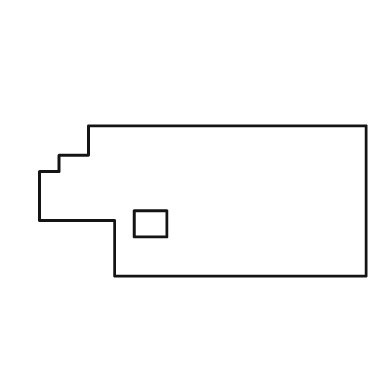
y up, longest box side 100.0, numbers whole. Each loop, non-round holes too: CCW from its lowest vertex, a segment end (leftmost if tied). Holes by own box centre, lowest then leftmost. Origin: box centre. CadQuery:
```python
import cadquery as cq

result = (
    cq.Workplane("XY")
    .moveTo(-27.0, -23.0)
    .lineTo(50.0, -23.0)
    .lineTo(50.0, 23.0)
    .lineTo(-35.0, 23.0)
    .lineTo(-35.0, 14.0)
    .lineTo(-44.0, 14.0)
    .lineTo(-44.0, 9.0)
    .lineTo(-50.0, 9.0)
    .lineTo(-50.0, -6.0)
    .lineTo(-27.0, -6.0)
    .close()
    .moveTo(-21.0, -11.0)
    .lineTo(-11.0, -11.0)
    .lineTo(-11.0, -3.0)
    .lineTo(-21.0, -3.0)
    .close()
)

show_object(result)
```